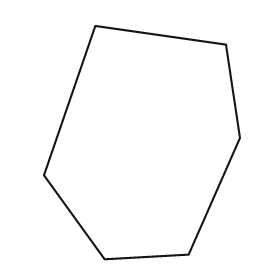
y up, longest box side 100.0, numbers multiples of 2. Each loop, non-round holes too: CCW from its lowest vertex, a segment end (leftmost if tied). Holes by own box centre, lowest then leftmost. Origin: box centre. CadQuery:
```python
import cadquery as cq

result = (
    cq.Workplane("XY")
    .moveTo(-16.0, -50.0)
    .lineTo(20.0, -48.0)
    .lineTo(42.0, 2.0)
    .lineTo(36.0, 42.0)
    .lineTo(-20.0, 50.0)
    .lineTo(-42.0, -14.0)
    .close()
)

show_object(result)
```